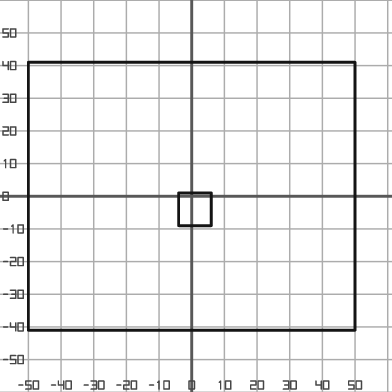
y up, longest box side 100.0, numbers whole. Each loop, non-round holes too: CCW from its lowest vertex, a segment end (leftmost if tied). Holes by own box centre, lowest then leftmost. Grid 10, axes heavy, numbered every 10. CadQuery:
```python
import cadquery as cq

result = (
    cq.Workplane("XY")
    .moveTo(-50.0, -41.0)
    .lineTo(50.0, -41.0)
    .lineTo(50.0, 41.0)
    .lineTo(-50.0, 41.0)
    .close()
    .moveTo(-4.0, -9.0)
    .lineTo(6.0, -9.0)
    .lineTo(6.0, 1.0)
    .lineTo(-4.0, 1.0)
    .close()
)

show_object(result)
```